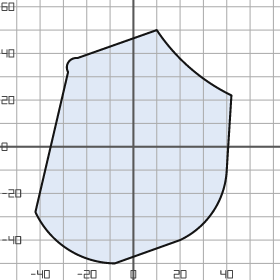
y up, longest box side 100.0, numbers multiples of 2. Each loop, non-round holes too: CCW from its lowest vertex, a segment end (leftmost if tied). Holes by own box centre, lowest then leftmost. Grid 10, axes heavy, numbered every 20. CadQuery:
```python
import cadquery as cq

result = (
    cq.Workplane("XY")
    .moveTo(-8.0, -50.0)
    .lineTo(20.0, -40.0)
    .threePointArc((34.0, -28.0), (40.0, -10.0))
    .lineTo(42.0, 22.0)
    .threePointArc((24.0, 34.0), (10.0, 50.0))
    .lineTo(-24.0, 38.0)
    .threePointArc((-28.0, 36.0), (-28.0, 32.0))
    .lineTo(-42.0, -28.0)
    .threePointArc((-28.0, -44.0), (-8.0, -50.0))
    .close()
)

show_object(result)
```